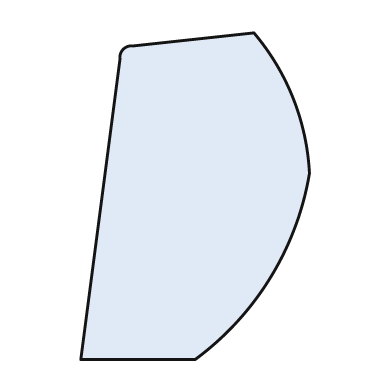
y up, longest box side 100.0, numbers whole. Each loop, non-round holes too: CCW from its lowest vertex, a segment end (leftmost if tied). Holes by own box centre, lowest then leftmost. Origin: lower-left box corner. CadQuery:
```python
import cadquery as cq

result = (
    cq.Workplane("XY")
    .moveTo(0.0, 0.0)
    .lineTo(35.0, 0.0)
    .threePointArc((58.0, 25.0), (70.0, 57.0))
    .threePointArc((65.0, 80.0), (53.0, 100.0))
    .lineTo(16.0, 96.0)
    .threePointArc((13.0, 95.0), (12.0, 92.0))
    .close()
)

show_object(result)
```